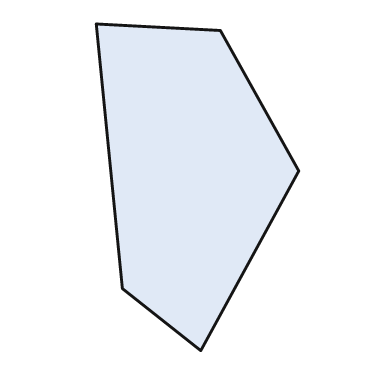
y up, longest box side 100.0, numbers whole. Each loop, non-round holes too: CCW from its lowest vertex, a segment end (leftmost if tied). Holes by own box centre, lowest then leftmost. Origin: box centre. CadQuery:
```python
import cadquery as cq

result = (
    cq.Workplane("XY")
    .moveTo(1.0, -50.0)
    .lineTo(31.0, 5.0)
    .lineTo(7.0, 48.0)
    .lineTo(-31.0, 50.0)
    .lineTo(-23.0, -31.0)
    .close()
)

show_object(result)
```